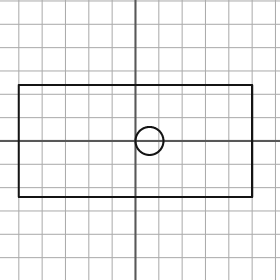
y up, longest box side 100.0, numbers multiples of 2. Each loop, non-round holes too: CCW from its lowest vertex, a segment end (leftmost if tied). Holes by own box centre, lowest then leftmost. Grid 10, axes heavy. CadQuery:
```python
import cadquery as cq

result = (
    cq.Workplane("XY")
    .moveTo(-50.0, -24.0)
    .lineTo(50.0, -24.0)
    .lineTo(50.0, 24.0)
    .lineTo(-50.0, 24.0)
    .close()
    .moveTo(6.0, 0.0)
    .circle(6.0)
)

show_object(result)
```